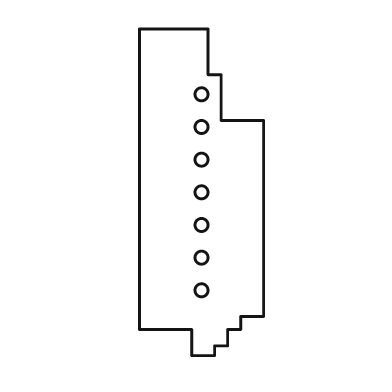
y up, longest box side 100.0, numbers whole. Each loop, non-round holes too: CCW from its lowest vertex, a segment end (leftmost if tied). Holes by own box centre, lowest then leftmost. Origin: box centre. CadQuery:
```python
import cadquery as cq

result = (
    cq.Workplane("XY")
    .moveTo(-3.0, -50.0)
    .lineTo(4.0, -50.0)
    .lineTo(4.0, -47.0)
    .lineTo(8.0, -47.0)
    .lineTo(8.0, -42.0)
    .lineTo(12.0, -42.0)
    .lineTo(12.0, -38.0)
    .lineTo(19.0, -38.0)
    .lineTo(19.0, 22.0)
    .lineTo(6.0, 22.0)
    .lineTo(6.0, 36.0)
    .lineTo(2.0, 36.0)
    .lineTo(2.0, 50.0)
    .lineTo(-19.0, 50.0)
    .lineTo(-19.0, -42.0)
    .lineTo(-3.0, -42.0)
    .close()
    .moveTo(0.0, -30.0)
    .circle(2.0)
    .moveTo(0.0, -20.0)
    .circle(2.0)
    .moveTo(0.0, -10.0)
    .circle(2.0)
    .moveTo(0.0, 0.0)
    .circle(2.0)
    .moveTo(0.0, 10.0)
    .circle(2.0)
    .moveTo(0.0, 20.0)
    .circle(2.0)
    .moveTo(0.0, 30.0)
    .circle(2.0)
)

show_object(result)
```